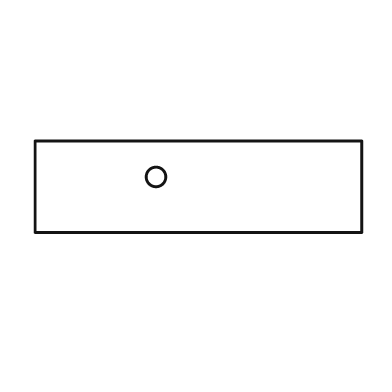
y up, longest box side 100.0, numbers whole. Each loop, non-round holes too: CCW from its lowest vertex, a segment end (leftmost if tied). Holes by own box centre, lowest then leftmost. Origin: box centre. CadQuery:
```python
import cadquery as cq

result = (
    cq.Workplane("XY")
    .moveTo(-50.0, -14.0)
    .lineTo(50.0, -14.0)
    .lineTo(50.0, 14.0)
    .lineTo(-50.0, 14.0)
    .close()
    .moveTo(-13.0, 3.0)
    .circle(3.0)
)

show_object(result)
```